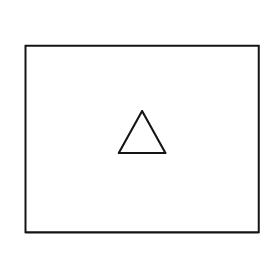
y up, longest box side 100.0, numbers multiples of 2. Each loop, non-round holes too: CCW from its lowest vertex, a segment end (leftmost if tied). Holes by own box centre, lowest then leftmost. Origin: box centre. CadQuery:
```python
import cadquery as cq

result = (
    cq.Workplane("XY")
    .moveTo(-50.0, -40.0)
    .lineTo(50.0, -40.0)
    .lineTo(50.0, 40.0)
    .lineTo(-50.0, 40.0)
    .close()
    .moveTo(-10.0, -6.0)
    .lineTo(10.0, -6.0)
    .lineTo(0.0, 12.0)
    .close()
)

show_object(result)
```